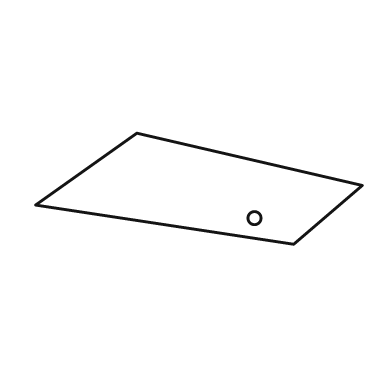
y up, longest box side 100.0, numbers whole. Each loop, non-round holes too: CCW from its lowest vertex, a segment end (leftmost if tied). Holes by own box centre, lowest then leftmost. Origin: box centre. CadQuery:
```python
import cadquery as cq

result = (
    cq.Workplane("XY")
    .moveTo(29.0, -17.0)
    .lineTo(50.0, 1.0)
    .lineTo(-19.0, 17.0)
    .lineTo(-50.0, -5.0)
    .close()
    .moveTo(17.0, -9.0)
    .circle(2.0)
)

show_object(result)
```